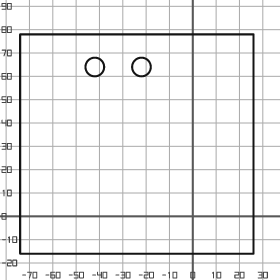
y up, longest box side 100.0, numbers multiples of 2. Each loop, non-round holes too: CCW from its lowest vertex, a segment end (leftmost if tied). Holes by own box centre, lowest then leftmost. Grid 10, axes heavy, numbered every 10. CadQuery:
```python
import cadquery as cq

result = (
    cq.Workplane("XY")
    .moveTo(-74.0, -16.0)
    .lineTo(26.0, -16.0)
    .lineTo(26.0, 78.0)
    .lineTo(-74.0, 78.0)
    .close()
    .moveTo(-42.0, 64.0)
    .circle(4.0)
    .moveTo(-22.0, 64.0)
    .circle(4.0)
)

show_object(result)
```